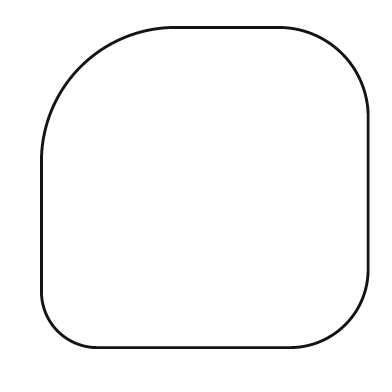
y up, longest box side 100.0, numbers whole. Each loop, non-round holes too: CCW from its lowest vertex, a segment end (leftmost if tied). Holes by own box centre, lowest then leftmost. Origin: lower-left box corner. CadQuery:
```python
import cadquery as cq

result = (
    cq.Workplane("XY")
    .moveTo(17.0, 0.0)
    .lineTo(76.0, 0.0)
    .threePointArc((93.0, 7.0), (100.0, 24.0))
    .lineTo(100.0, 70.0)
    .threePointArc((92.0, 90.0), (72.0, 98.0))
    .lineTo(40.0, 98.0)
    .threePointArc((12.0, 86.0), (0.0, 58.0))
    .lineTo(0.0, 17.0)
    .threePointArc((5.0, 5.0), (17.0, 0.0))
    .close()
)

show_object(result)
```